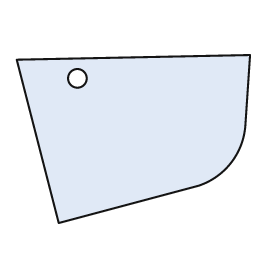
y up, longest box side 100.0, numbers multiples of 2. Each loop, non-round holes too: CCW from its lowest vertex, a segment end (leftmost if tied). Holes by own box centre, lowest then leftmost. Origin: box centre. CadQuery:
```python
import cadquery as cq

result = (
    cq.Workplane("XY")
    .moveTo(-32.0, -36.0)
    .lineTo(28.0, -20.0)
    .threePointArc((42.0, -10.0), (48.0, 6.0))
    .lineTo(50.0, 36.0)
    .lineTo(-50.0, 34.0)
    .close()
    .moveTo(-24.0, 26.0)
    .circle(4.0)
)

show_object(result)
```